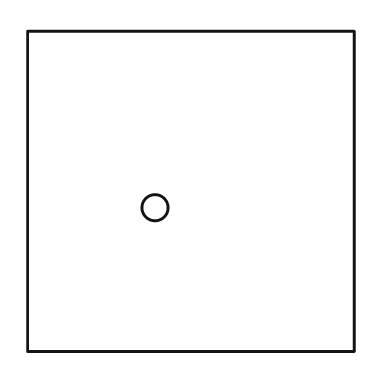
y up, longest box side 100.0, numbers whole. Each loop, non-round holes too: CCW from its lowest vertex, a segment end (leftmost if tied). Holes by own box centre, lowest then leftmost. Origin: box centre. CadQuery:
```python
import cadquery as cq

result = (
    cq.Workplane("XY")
    .moveTo(-50.0, -49.0)
    .lineTo(50.0, -49.0)
    .lineTo(50.0, 49.0)
    .lineTo(-50.0, 49.0)
    .close()
    .moveTo(-11.0, -5.0)
    .circle(4.0)
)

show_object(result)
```